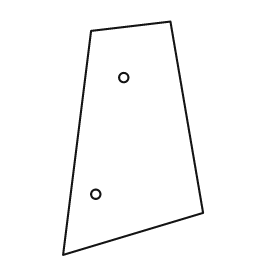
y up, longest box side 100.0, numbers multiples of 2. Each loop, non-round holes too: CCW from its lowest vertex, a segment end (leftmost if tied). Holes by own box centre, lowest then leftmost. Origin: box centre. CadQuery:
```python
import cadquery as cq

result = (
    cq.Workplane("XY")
    .moveTo(-30.0, -50.0)
    .lineTo(30.0, -32.0)
    .lineTo(16.0, 50.0)
    .lineTo(-18.0, 46.0)
    .close()
    .moveTo(-16.0, -24.0)
    .circle(2.0)
    .moveTo(-4.0, 26.0)
    .circle(2.0)
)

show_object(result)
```